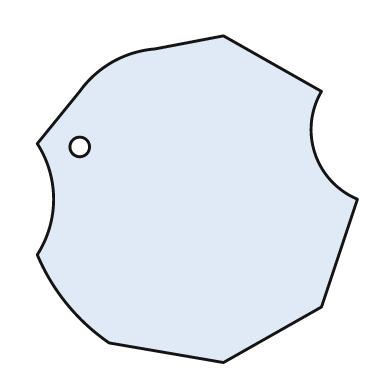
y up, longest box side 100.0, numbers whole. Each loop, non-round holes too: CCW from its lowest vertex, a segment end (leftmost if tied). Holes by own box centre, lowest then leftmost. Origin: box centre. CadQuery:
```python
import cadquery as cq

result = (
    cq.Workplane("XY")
    .moveTo(8.0, -50.0)
    .lineTo(38.0, -33.0)
    .lineTo(49.0, 0.0)
    .threePointArc((36.0, 14.0), (38.0, 33.0))
    .lineTo(8.0, 50.0)
    .lineTo(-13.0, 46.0)
    .threePointArc((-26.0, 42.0), (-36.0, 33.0))
    .lineTo(-49.0, 17.0)
    .threePointArc((-44.0, 0.0), (-49.0, -17.0))
    .threePointArc((-40.0, -32.0), (-27.0, -44.0))
    .close()
    .moveTo(-36.0, 16.0)
    .circle(3.0)
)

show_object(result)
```